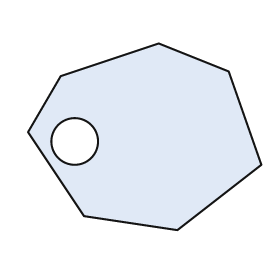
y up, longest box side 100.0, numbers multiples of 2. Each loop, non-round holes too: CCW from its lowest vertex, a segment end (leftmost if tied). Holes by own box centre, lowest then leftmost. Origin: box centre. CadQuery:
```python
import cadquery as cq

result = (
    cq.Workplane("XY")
    .moveTo(14.0, -40.0)
    .lineTo(50.0, -12.0)
    .lineTo(36.0, 28.0)
    .lineTo(6.0, 40.0)
    .lineTo(-36.0, 26.0)
    .lineTo(-50.0, 2.0)
    .lineTo(-26.0, -34.0)
    .close()
    .moveTo(-30.0, -2.0)
    .circle(10.0)
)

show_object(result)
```